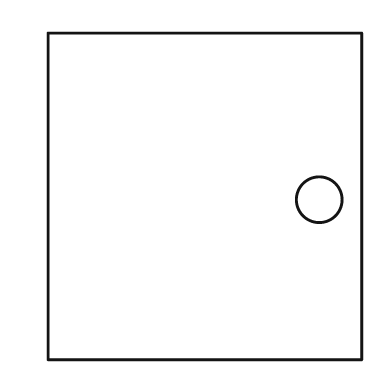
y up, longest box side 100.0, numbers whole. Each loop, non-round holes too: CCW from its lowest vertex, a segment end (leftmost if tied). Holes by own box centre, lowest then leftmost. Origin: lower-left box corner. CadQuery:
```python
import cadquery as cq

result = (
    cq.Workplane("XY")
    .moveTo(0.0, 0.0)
    .lineTo(96.0, 0.0)
    .lineTo(96.0, 100.0)
    .lineTo(0.0, 100.0)
    .close()
    .moveTo(83.0, 49.0)
    .circle(7.0)
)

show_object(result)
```